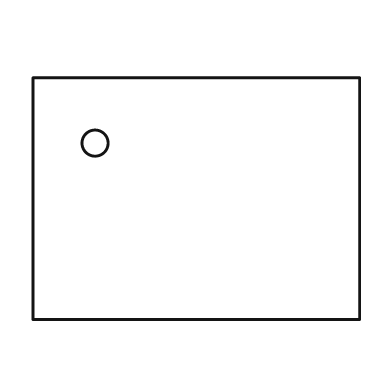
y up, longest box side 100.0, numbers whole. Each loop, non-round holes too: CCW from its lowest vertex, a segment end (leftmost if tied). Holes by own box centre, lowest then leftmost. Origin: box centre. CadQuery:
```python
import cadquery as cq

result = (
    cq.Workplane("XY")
    .moveTo(-50.0, -37.0)
    .lineTo(50.0, -37.0)
    .lineTo(50.0, 37.0)
    .lineTo(-50.0, 37.0)
    .close()
    .moveTo(-31.0, 17.0)
    .circle(4.0)
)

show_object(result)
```